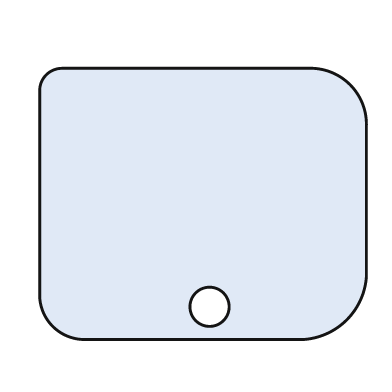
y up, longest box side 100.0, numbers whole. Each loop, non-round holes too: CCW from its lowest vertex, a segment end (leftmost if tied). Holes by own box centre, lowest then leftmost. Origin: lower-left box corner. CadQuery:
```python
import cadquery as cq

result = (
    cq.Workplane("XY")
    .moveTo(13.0, 0.0)
    .lineTo(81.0, 0.0)
    .threePointArc((94.0, 6.0), (100.0, 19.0))
    .lineTo(100.0, 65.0)
    .threePointArc((95.0, 78.0), (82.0, 83.0))
    .lineTo(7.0, 83.0)
    .threePointArc((2.0, 81.0), (0.0, 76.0))
    .lineTo(0.0, 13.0)
    .threePointArc((4.0, 4.0), (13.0, 0.0))
    .close()
    .moveTo(52.0, 10.0)
    .circle(6.0)
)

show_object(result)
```